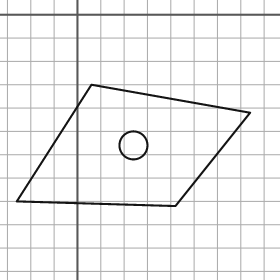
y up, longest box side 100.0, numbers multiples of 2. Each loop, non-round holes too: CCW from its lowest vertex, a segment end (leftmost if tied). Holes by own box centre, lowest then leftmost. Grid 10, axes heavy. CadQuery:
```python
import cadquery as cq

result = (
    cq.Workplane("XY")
    .moveTo(42.0, -82.0)
    .lineTo(74.0, -42.0)
    .lineTo(6.0, -30.0)
    .lineTo(-26.0, -80.0)
    .close()
    .moveTo(24.0, -56.0)
    .circle(6.0)
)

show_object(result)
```